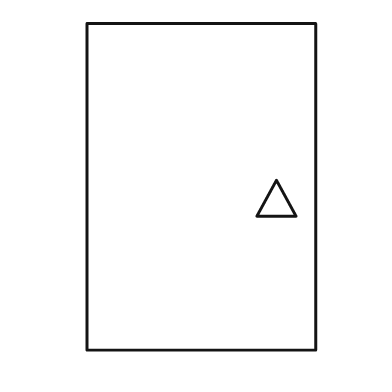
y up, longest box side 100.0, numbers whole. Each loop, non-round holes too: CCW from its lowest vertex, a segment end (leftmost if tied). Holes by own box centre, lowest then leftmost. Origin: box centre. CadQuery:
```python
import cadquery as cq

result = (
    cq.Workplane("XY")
    .moveTo(-35.0, -50.0)
    .lineTo(35.0, -50.0)
    .lineTo(35.0, 50.0)
    .lineTo(-35.0, 50.0)
    .close()
    .moveTo(17.0, -9.0)
    .lineTo(29.0, -9.0)
    .lineTo(23.0, 2.0)
    .close()
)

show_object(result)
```